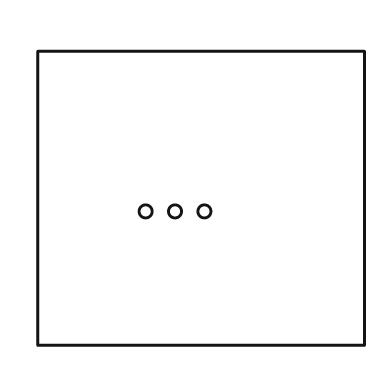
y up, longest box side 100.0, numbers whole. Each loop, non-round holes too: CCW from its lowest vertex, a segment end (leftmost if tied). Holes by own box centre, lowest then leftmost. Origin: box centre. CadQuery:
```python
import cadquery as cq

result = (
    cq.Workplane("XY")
    .moveTo(-50.0, -45.0)
    .lineTo(50.0, -45.0)
    .lineTo(50.0, 45.0)
    .lineTo(-50.0, 45.0)
    .close()
    .moveTo(-17.0, -4.0)
    .circle(2.0)
    .moveTo(-8.0, -4.0)
    .circle(2.0)
    .moveTo(1.0, -4.0)
    .circle(2.0)
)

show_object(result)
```